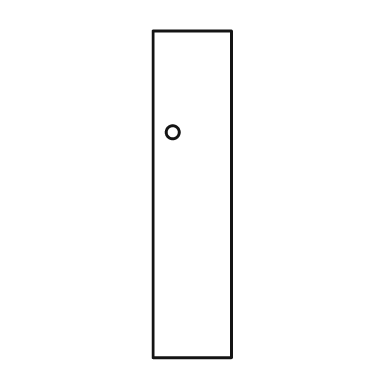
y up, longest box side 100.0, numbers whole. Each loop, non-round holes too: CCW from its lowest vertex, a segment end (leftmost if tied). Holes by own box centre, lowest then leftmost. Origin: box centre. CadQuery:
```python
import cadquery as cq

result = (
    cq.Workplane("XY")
    .moveTo(-12.0, -50.0)
    .lineTo(12.0, -50.0)
    .lineTo(12.0, 50.0)
    .lineTo(-12.0, 50.0)
    .close()
    .moveTo(-6.0, 19.0)
    .circle(2.0)
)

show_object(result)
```